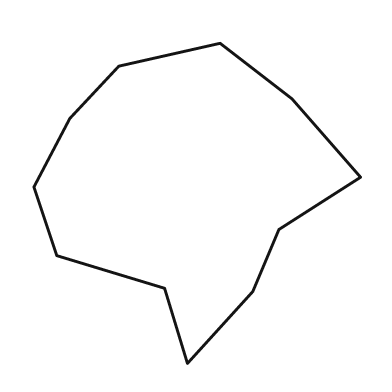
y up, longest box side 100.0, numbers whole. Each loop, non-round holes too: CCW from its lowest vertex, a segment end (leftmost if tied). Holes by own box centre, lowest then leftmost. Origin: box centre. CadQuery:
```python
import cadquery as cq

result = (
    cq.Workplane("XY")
    .moveTo(-3.0, -49.0)
    .lineTo(17.0, -27.0)
    .lineTo(25.0, -8.0)
    .lineTo(50.0, 8.0)
    .lineTo(29.0, 32.0)
    .lineTo(7.0, 49.0)
    .lineTo(-24.0, 42.0)
    .lineTo(-39.0, 26.0)
    .lineTo(-50.0, 5.0)
    .lineTo(-43.0, -16.0)
    .lineTo(-10.0, -26.0)
    .close()
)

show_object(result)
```